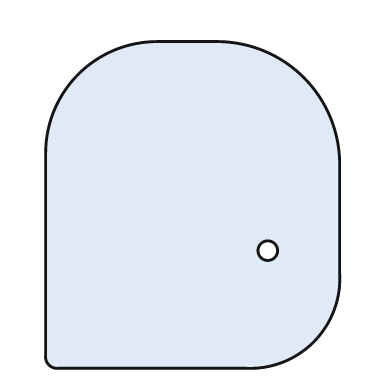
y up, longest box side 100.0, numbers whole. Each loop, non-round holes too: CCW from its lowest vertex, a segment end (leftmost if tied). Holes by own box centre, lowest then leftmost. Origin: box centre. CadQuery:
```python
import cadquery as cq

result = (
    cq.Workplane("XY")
    .moveTo(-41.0, -50.0)
    .lineTo(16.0, -50.0)
    .threePointArc((37.0, -42.0), (45.0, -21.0))
    .lineTo(45.0, 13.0)
    .threePointArc((34.0, 39.0), (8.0, 50.0))
    .lineTo(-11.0, 50.0)
    .threePointArc((-35.0, 40.0), (-45.0, 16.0))
    .lineTo(-45.0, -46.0)
    .threePointArc((-44.0, -49.0), (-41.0, -50.0))
    .close()
    .moveTo(23.0, -14.0)
    .circle(3.0)
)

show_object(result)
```